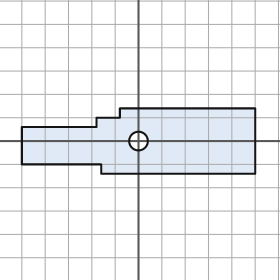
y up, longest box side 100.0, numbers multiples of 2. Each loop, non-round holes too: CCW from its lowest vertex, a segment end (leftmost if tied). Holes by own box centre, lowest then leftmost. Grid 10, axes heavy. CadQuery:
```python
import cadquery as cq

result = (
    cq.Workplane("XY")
    .moveTo(-16.0, -14.0)
    .lineTo(50.0, -14.0)
    .lineTo(50.0, 14.0)
    .lineTo(-8.0, 14.0)
    .lineTo(-8.0, 10.0)
    .lineTo(-18.0, 10.0)
    .lineTo(-18.0, 6.0)
    .lineTo(-50.0, 6.0)
    .lineTo(-50.0, -10.0)
    .lineTo(-16.0, -10.0)
    .close()
    .moveTo(0.0, 0.0)
    .circle(4.0)
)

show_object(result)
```